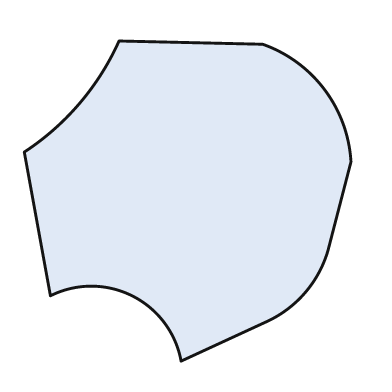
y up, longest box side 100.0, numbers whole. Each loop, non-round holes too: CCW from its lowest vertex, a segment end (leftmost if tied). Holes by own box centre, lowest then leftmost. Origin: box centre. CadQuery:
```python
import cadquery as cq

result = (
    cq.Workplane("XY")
    .moveTo(-2.0, -49.0)
    .lineTo(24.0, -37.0)
    .threePointArc((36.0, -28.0), (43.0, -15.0))
    .lineTo(50.0, 12.0)
    .threePointArc((42.0, 34.0), (23.0, 48.0))
    .lineTo(-21.0, 49.0)
    .threePointArc((-33.0, 30.0), (-50.0, 15.0))
    .lineTo(-42.0, -29.0)
    .threePointArc((-17.0, -29.0), (-2.0, -49.0))
    .close()
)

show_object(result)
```